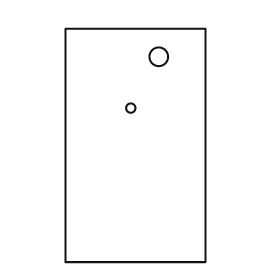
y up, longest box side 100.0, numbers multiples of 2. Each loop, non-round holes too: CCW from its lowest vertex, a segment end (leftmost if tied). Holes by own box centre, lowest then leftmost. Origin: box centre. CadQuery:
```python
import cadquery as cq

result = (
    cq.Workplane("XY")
    .moveTo(-30.0, -50.0)
    .lineTo(30.0, -50.0)
    .lineTo(30.0, 50.0)
    .lineTo(-30.0, 50.0)
    .close()
    .moveTo(-2.0, 16.0)
    .circle(2.0)
    .moveTo(10.0, 38.0)
    .circle(4.0)
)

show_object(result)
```